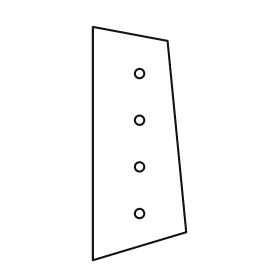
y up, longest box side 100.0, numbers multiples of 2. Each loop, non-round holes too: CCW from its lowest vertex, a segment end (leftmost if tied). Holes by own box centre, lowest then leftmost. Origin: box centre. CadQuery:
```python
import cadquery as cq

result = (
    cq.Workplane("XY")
    .moveTo(-20.0, -50.0)
    .lineTo(20.0, -38.0)
    .lineTo(12.0, 44.0)
    .lineTo(-20.0, 50.0)
    .close()
    .moveTo(0.0, -30.0)
    .circle(2.0)
    .moveTo(0.0, -10.0)
    .circle(2.0)
    .moveTo(0.0, 10.0)
    .circle(2.0)
    .moveTo(0.0, 30.0)
    .circle(2.0)
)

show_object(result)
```